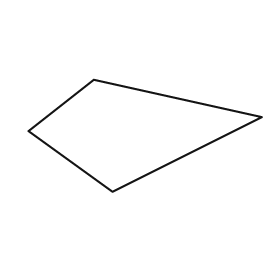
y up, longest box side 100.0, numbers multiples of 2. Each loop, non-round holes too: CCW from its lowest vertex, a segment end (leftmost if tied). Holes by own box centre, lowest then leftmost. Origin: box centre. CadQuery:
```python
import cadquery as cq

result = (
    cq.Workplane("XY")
    .moveTo(-14.0, -24.0)
    .lineTo(50.0, 8.0)
    .lineTo(-22.0, 24.0)
    .lineTo(-50.0, 2.0)
    .close()
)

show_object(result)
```